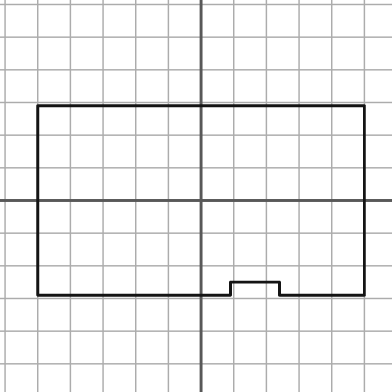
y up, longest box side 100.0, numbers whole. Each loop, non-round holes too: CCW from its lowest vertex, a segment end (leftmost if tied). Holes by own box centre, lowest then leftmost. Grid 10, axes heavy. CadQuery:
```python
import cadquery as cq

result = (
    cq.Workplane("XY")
    .moveTo(-50.0, -29.0)
    .lineTo(9.0, -29.0)
    .lineTo(9.0, -25.0)
    .lineTo(24.0, -25.0)
    .lineTo(24.0, -29.0)
    .lineTo(50.0, -29.0)
    .lineTo(50.0, 29.0)
    .lineTo(-50.0, 29.0)
    .close()
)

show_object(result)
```